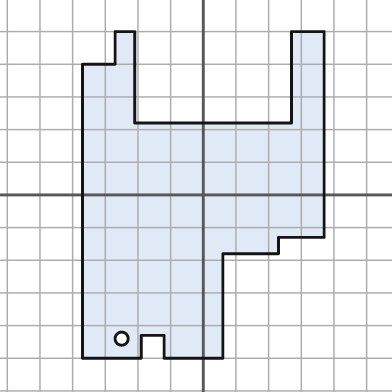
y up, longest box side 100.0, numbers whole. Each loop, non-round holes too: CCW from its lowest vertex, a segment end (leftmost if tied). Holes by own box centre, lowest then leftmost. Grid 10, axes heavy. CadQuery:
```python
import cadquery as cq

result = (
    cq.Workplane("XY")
    .moveTo(-37.0, -50.0)
    .lineTo(-19.0, -50.0)
    .lineTo(-19.0, -43.0)
    .lineTo(-12.0, -43.0)
    .lineTo(-12.0, -50.0)
    .lineTo(6.0, -50.0)
    .lineTo(6.0, -18.0)
    .lineTo(23.0, -18.0)
    .lineTo(23.0, -13.0)
    .lineTo(37.0, -13.0)
    .lineTo(37.0, 50.0)
    .lineTo(27.0, 50.0)
    .lineTo(27.0, 22.0)
    .lineTo(-21.0, 22.0)
    .lineTo(-21.0, 50.0)
    .lineTo(-27.0, 50.0)
    .lineTo(-27.0, 40.0)
    .lineTo(-37.0, 40.0)
    .close()
    .moveTo(-25.0, -44.0)
    .circle(2.0)
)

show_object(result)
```